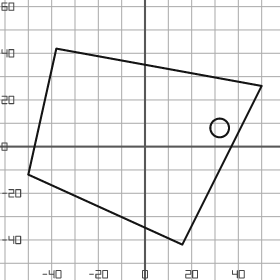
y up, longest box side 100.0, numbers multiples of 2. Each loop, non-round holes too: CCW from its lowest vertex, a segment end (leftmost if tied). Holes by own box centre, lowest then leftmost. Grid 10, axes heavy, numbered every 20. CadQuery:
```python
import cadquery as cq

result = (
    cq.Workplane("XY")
    .moveTo(16.0, -42.0)
    .lineTo(50.0, 26.0)
    .lineTo(-38.0, 42.0)
    .lineTo(-50.0, -12.0)
    .close()
    .moveTo(32.0, 8.0)
    .circle(4.0)
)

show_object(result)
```